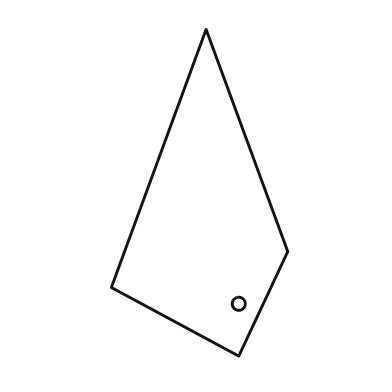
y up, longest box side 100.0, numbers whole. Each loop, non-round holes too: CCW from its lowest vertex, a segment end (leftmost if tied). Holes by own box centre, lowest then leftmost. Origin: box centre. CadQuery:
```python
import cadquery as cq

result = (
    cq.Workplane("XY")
    .moveTo(12.0, -50.0)
    .lineTo(27.0, -18.0)
    .lineTo(2.0, 50.0)
    .lineTo(-27.0, -29.0)
    .close()
    .moveTo(12.0, -34.0)
    .circle(2.0)
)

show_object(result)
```